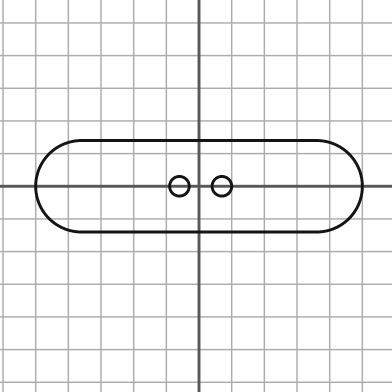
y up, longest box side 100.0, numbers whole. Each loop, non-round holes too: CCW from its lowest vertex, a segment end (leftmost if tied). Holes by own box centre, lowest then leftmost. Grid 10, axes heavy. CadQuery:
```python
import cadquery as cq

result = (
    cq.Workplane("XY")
    .moveTo(-36.0, -14.0)
    .lineTo(36.0, -14.0)
    .threePointArc((50.0, 0.0), (36.0, 14.0))
    .lineTo(-36.0, 14.0)
    .threePointArc((-50.0, 0.0), (-36.0, -14.0))
    .close()
    .moveTo(-6.0, 0.0)
    .circle(3.0)
    .moveTo(7.0, 0.0)
    .circle(3.0)
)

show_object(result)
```